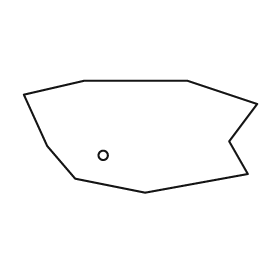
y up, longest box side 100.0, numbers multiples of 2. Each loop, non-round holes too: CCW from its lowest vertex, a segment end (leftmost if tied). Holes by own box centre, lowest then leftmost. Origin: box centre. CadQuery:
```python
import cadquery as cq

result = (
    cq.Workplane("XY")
    .moveTo(2.0, -24.0)
    .lineTo(46.0, -16.0)
    .lineTo(38.0, -2.0)
    .lineTo(50.0, 14.0)
    .lineTo(20.0, 24.0)
    .lineTo(-24.0, 24.0)
    .lineTo(-50.0, 18.0)
    .lineTo(-40.0, -4.0)
    .lineTo(-28.0, -18.0)
    .close()
    .moveTo(-16.0, -8.0)
    .circle(2.0)
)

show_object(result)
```